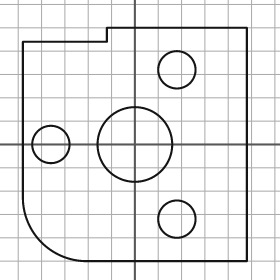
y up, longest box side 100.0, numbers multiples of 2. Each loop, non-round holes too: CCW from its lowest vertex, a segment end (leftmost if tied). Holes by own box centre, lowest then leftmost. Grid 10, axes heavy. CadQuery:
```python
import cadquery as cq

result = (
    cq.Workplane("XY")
    .moveTo(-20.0, -50.0)
    .lineTo(48.0, -50.0)
    .lineTo(48.0, 50.0)
    .lineTo(-12.0, 50.0)
    .lineTo(-12.0, 44.0)
    .lineTo(-48.0, 44.0)
    .lineTo(-48.0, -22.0)
    .threePointArc((-40.0, -42.0), (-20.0, -50.0))
    .close()
    .moveTo(18.0, -32.0)
    .circle(8.0)
    .moveTo(-36.0, 0.0)
    .circle(8.0)
    .moveTo(0.0, 0.0)
    .circle(16.0)
    .moveTo(18.0, 32.0)
    .circle(8.0)
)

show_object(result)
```